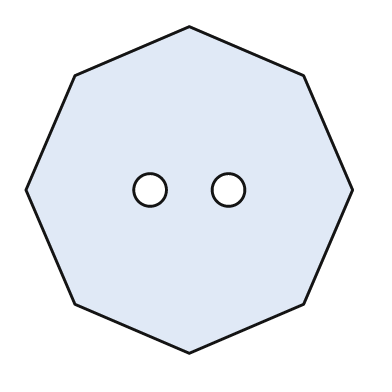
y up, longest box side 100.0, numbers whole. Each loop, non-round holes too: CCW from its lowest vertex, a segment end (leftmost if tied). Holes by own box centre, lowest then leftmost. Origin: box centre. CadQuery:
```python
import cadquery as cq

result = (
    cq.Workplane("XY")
    .moveTo(0.0, -50.0)
    .lineTo(35.0, -35.0)
    .lineTo(50.0, 0.0)
    .lineTo(35.0, 35.0)
    .lineTo(0.0, 50.0)
    .lineTo(-35.0, 35.0)
    .lineTo(-50.0, 0.0)
    .lineTo(-35.0, -35.0)
    .close()
    .moveTo(-12.0, 0.0)
    .circle(5.0)
    .moveTo(12.0, 0.0)
    .circle(5.0)
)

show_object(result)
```